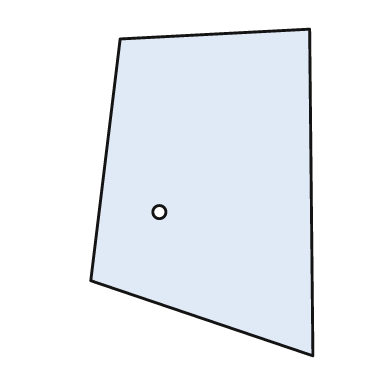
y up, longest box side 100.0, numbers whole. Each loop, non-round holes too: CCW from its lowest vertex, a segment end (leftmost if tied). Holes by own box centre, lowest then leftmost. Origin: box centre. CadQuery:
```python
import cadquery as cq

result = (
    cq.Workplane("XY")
    .moveTo(34.0, -50.0)
    .lineTo(33.0, 50.0)
    .lineTo(-25.0, 47.0)
    .lineTo(-34.0, -27.0)
    .close()
    .moveTo(-13.0, -6.0)
    .circle(2.0)
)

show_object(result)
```